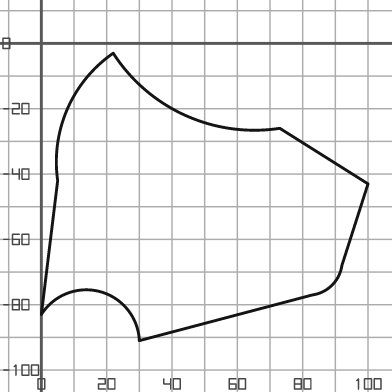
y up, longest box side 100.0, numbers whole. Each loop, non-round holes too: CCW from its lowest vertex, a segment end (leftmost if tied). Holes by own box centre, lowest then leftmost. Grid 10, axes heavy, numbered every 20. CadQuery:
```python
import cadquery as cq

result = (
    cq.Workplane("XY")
    .moveTo(30.0, -91.0)
    .lineTo(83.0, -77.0)
    .threePointArc((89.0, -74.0), (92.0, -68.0))
    .lineTo(100.0, -43.0)
    .lineTo(73.0, -26.0)
    .threePointArc((44.0, -22.0), (22.0, -3.0))
    .threePointArc((8.0, -20.0), (5.0, -42.0))
    .lineTo(0.0, -83.0)
    .threePointArc((18.0, -76.0), (30.0, -91.0))
    .close()
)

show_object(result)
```